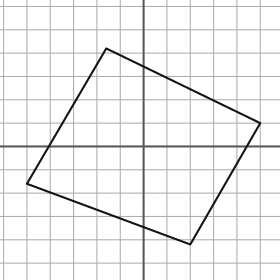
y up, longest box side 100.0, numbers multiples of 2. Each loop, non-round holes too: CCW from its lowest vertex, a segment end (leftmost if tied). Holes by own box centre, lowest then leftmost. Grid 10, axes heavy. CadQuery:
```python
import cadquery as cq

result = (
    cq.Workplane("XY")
    .moveTo(20.0, -42.0)
    .lineTo(50.0, 10.0)
    .lineTo(-16.0, 42.0)
    .lineTo(-50.0, -16.0)
    .close()
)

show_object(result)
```